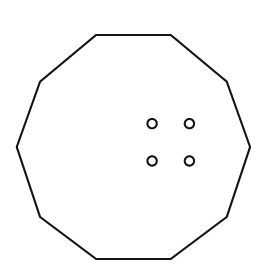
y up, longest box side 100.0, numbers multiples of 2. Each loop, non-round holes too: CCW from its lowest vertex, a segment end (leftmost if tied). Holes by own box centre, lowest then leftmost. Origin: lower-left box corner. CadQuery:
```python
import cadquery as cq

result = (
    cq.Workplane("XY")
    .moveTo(34.0, 0.0)
    .lineTo(66.0, 0.0)
    .lineTo(90.0, 18.0)
    .lineTo(100.0, 48.0)
    .lineTo(90.0, 76.0)
    .lineTo(66.0, 96.0)
    .lineTo(34.0, 96.0)
    .lineTo(10.0, 76.0)
    .lineTo(0.0, 48.0)
    .lineTo(10.0, 18.0)
    .close()
    .moveTo(58.0, 42.0)
    .circle(2.0)
    .moveTo(74.0, 42.0)
    .circle(2.0)
    .moveTo(58.0, 58.0)
    .circle(2.0)
    .moveTo(74.0, 58.0)
    .circle(2.0)
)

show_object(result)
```